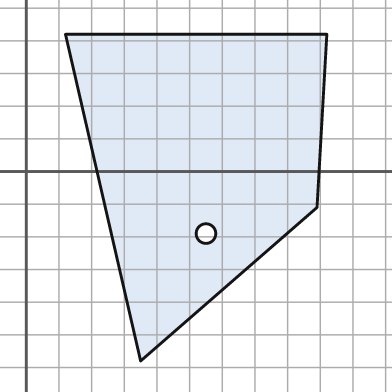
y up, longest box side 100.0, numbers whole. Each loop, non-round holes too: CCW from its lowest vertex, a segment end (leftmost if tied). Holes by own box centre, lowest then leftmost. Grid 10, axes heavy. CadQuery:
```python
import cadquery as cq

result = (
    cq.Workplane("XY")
    .moveTo(35.0, -58.0)
    .lineTo(89.0, -11.0)
    .lineTo(92.0, 42.0)
    .lineTo(12.0, 42.0)
    .close()
    .moveTo(55.0, -19.0)
    .circle(3.0)
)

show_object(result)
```